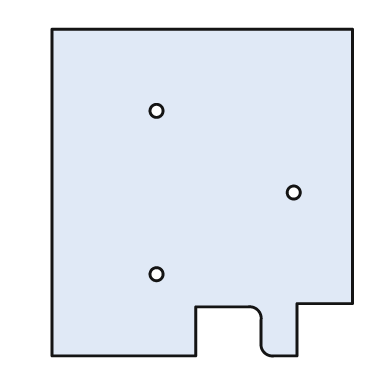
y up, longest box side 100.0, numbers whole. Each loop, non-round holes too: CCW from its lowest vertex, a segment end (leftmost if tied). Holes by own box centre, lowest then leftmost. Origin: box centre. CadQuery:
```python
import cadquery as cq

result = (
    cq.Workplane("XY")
    .moveTo(-46.0, -50.0)
    .lineTo(-2.0, -50.0)
    .lineTo(-2.0, -35.0)
    .lineTo(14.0, -35.0)
    .threePointArc((17.0, -36.0), (18.0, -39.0))
    .lineTo(18.0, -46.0)
    .threePointArc((19.0, -49.0), (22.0, -50.0))
    .lineTo(29.0, -50.0)
    .lineTo(29.0, -34.0)
    .lineTo(46.0, -34.0)
    .lineTo(46.0, 50.0)
    .lineTo(-46.0, 50.0)
    .close()
    .moveTo(-14.0, -25.0)
    .circle(2.0)
    .moveTo(28.0, 0.0)
    .circle(2.0)
    .moveTo(-14.0, 25.0)
    .circle(2.0)
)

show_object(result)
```